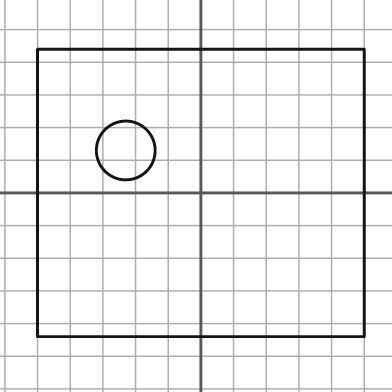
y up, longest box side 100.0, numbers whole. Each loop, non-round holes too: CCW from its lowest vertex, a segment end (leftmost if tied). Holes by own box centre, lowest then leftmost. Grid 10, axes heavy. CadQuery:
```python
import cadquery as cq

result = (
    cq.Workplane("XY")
    .moveTo(-50.0, -44.0)
    .lineTo(50.0, -44.0)
    .lineTo(50.0, 44.0)
    .lineTo(-50.0, 44.0)
    .close()
    .moveTo(-23.0, 13.0)
    .circle(9.0)
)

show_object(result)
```